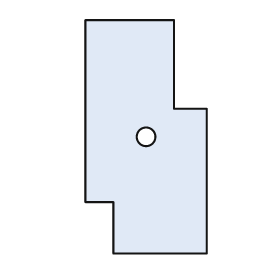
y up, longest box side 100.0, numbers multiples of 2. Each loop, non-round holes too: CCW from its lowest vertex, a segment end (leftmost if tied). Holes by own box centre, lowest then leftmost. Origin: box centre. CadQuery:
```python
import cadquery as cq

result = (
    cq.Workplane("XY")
    .moveTo(-14.0, -50.0)
    .lineTo(26.0, -50.0)
    .lineTo(26.0, 12.0)
    .lineTo(12.0, 12.0)
    .lineTo(12.0, 50.0)
    .lineTo(-26.0, 50.0)
    .lineTo(-26.0, -28.0)
    .lineTo(-14.0, -28.0)
    .close()
    .moveTo(0.0, 0.0)
    .circle(4.0)
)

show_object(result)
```